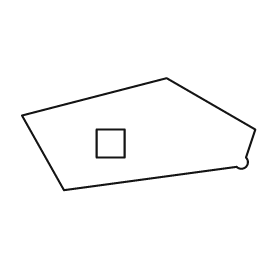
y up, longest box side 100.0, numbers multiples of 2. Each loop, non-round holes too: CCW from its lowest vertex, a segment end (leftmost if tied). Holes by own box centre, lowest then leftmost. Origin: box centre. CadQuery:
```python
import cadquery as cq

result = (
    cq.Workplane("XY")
    .moveTo(-32.0, -24.0)
    .lineTo(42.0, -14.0)
    .threePointArc((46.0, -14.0), (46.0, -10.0))
    .lineTo(50.0, 2.0)
    .lineTo(12.0, 24.0)
    .lineTo(-50.0, 8.0)
    .close()
    .moveTo(-18.0, -10.0)
    .lineTo(-6.0, -10.0)
    .lineTo(-6.0, 2.0)
    .lineTo(-18.0, 2.0)
    .close()
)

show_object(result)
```